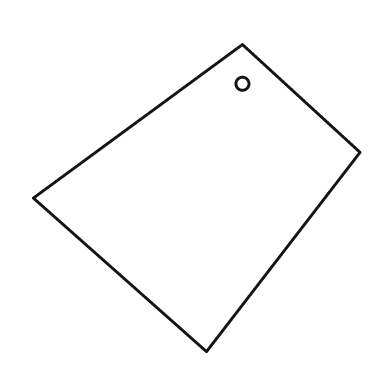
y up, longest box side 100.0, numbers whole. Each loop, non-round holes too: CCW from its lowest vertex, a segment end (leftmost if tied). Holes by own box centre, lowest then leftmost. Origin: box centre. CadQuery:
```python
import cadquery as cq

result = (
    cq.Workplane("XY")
    .moveTo(3.0, -47.0)
    .lineTo(50.0, 14.0)
    .lineTo(14.0, 47.0)
    .lineTo(-50.0, 0.0)
    .close()
    .moveTo(14.0, 35.0)
    .circle(2.0)
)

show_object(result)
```